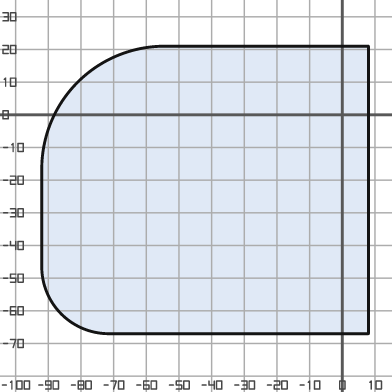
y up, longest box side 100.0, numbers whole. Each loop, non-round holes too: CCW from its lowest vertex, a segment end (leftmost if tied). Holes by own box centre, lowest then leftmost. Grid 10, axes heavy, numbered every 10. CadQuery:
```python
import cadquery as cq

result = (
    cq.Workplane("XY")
    .moveTo(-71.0, -67.0)
    .lineTo(8.0, -67.0)
    .lineTo(8.0, 21.0)
    .lineTo(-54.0, 21.0)
    .threePointArc((-81.0, 10.0), (-92.0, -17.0))
    .lineTo(-92.0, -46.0)
    .threePointArc((-86.0, -61.0), (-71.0, -67.0))
    .close()
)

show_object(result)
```